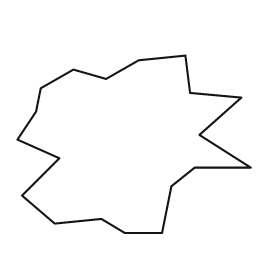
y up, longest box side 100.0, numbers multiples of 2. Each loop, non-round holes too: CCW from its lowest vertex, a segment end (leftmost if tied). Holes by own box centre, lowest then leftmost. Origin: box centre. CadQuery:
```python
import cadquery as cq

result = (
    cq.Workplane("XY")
    .moveTo(-4.0, -38.0)
    .lineTo(12.0, -38.0)
    .lineTo(16.0, -18.0)
    .lineTo(26.0, -10.0)
    .lineTo(50.0, -10.0)
    .lineTo(28.0, 4.0)
    .lineTo(46.0, 20.0)
    .lineTo(24.0, 22.0)
    .lineTo(22.0, 38.0)
    .lineTo(2.0, 36.0)
    .lineTo(-12.0, 28.0)
    .lineTo(-26.0, 32.0)
    .lineTo(-40.0, 24.0)
    .lineTo(-42.0, 14.0)
    .lineTo(-50.0, 2.0)
    .lineTo(-32.0, -6.0)
    .lineTo(-48.0, -22.0)
    .lineTo(-34.0, -34.0)
    .lineTo(-14.0, -32.0)
    .close()
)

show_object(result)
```